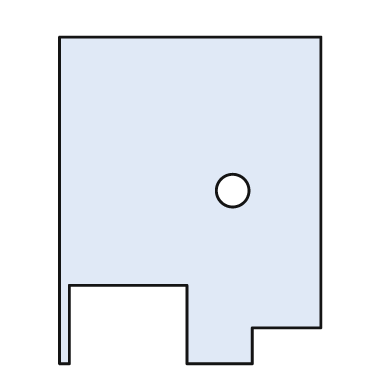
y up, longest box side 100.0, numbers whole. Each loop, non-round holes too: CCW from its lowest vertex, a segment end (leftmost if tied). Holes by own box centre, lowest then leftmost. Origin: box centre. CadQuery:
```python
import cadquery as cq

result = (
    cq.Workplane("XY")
    .moveTo(-40.0, -50.0)
    .lineTo(-37.0, -50.0)
    .lineTo(-37.0, -26.0)
    .lineTo(-1.0, -26.0)
    .lineTo(-1.0, -50.0)
    .lineTo(19.0, -50.0)
    .lineTo(19.0, -39.0)
    .lineTo(40.0, -39.0)
    .lineTo(40.0, 50.0)
    .lineTo(-40.0, 50.0)
    .close()
    .moveTo(13.0, 3.0)
    .circle(5.0)
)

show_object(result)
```